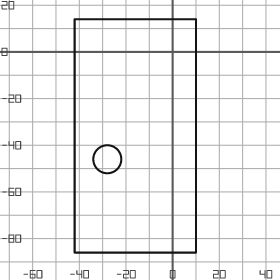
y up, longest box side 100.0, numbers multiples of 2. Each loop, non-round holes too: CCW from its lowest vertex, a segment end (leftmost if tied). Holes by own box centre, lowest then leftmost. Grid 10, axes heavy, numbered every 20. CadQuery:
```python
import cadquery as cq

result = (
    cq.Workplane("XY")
    .moveTo(-42.0, -86.0)
    .lineTo(10.0, -86.0)
    .lineTo(10.0, 14.0)
    .lineTo(-42.0, 14.0)
    .close()
    .moveTo(-28.0, -46.0)
    .circle(6.0)
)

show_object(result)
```